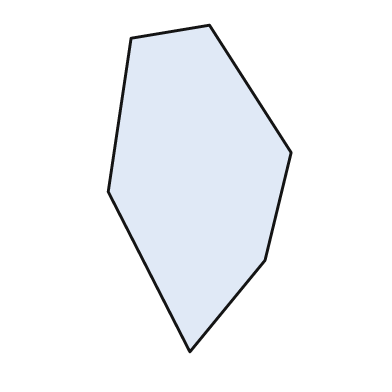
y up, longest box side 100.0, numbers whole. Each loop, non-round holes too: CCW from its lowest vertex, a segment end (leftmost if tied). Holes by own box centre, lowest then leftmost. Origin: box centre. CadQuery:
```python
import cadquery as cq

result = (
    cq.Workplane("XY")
    .moveTo(-3.0, -50.0)
    .lineTo(20.0, -22.0)
    .lineTo(28.0, 11.0)
    .lineTo(3.0, 50.0)
    .lineTo(-21.0, 46.0)
    .lineTo(-28.0, -1.0)
    .close()
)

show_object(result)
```